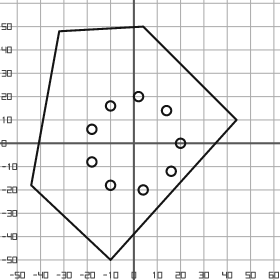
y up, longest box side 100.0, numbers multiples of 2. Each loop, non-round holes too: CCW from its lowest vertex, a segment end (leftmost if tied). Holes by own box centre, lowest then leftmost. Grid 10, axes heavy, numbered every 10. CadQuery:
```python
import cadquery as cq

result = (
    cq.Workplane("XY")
    .moveTo(-10.0, -50.0)
    .lineTo(44.0, 10.0)
    .lineTo(4.0, 50.0)
    .lineTo(-32.0, 48.0)
    .lineTo(-44.0, -18.0)
    .close()
    .moveTo(4.0, -20.0)
    .circle(2.0)
    .moveTo(-10.0, -18.0)
    .circle(2.0)
    .moveTo(16.0, -12.0)
    .circle(2.0)
    .moveTo(-18.0, -8.0)
    .circle(2.0)
    .moveTo(20.0, 0.0)
    .circle(2.0)
    .moveTo(-18.0, 6.0)
    .circle(2.0)
    .moveTo(14.0, 14.0)
    .circle(2.0)
    .moveTo(-10.0, 16.0)
    .circle(2.0)
    .moveTo(2.0, 20.0)
    .circle(2.0)
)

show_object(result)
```